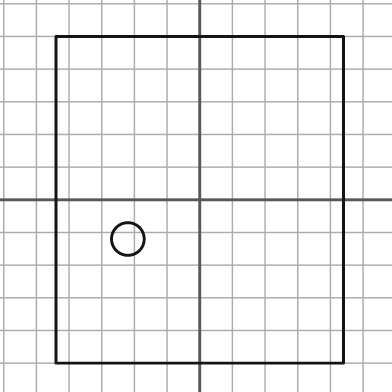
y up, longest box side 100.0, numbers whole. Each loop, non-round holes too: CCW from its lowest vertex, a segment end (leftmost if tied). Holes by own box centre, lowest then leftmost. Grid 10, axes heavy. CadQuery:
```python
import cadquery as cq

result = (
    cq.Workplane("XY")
    .moveTo(-44.0, -50.0)
    .lineTo(44.0, -50.0)
    .lineTo(44.0, 50.0)
    .lineTo(-44.0, 50.0)
    .close()
    .moveTo(-22.0, -12.0)
    .circle(5.0)
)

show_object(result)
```